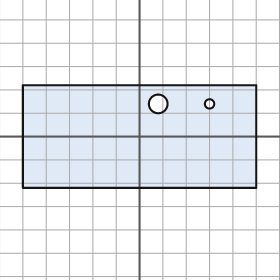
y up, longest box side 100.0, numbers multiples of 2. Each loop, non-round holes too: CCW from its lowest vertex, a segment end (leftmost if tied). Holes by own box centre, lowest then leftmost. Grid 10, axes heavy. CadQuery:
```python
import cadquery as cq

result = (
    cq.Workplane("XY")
    .moveTo(-50.0, -22.0)
    .lineTo(50.0, -22.0)
    .lineTo(50.0, 22.0)
    .lineTo(-50.0, 22.0)
    .close()
    .moveTo(8.0, 14.0)
    .circle(4.0)
    .moveTo(30.0, 14.0)
    .circle(2.0)
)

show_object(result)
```